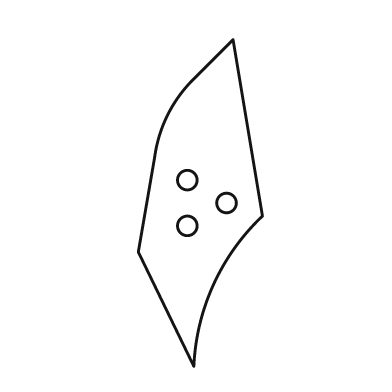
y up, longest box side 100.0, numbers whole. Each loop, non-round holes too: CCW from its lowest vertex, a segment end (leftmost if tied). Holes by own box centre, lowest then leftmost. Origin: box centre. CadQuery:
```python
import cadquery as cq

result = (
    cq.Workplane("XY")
    .moveTo(-2.0, -50.0)
    .threePointArc((4.0, -25.0), (19.0, -4.0))
    .lineTo(10.0, 50.0)
    .lineTo(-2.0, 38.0)
    .threePointArc((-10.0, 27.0), (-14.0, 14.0))
    .lineTo(-19.0, -15.0)
    .close()
    .moveTo(-4.0, -7.0)
    .circle(3.0)
    .moveTo(8.0, 0.0)
    .circle(3.0)
    .moveTo(-4.0, 7.0)
    .circle(3.0)
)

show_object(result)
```